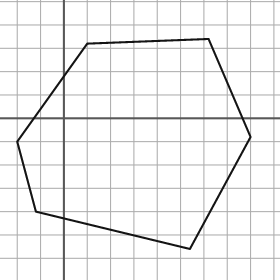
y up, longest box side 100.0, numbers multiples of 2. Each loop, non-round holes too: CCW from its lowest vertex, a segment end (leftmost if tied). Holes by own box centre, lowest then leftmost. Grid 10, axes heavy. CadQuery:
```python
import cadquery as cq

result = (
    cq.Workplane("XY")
    .moveTo(54.0, -56.0)
    .lineTo(80.0, -8.0)
    .lineTo(62.0, 34.0)
    .lineTo(10.0, 32.0)
    .lineTo(-20.0, -10.0)
    .lineTo(-12.0, -40.0)
    .close()
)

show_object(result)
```